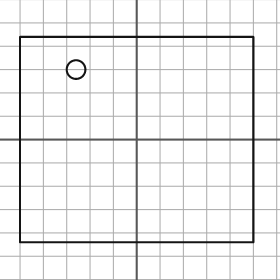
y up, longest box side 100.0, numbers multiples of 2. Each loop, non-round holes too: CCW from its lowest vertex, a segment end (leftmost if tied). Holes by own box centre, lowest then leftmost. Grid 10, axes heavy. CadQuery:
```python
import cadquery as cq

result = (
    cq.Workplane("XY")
    .moveTo(-50.0, -44.0)
    .lineTo(50.0, -44.0)
    .lineTo(50.0, 44.0)
    .lineTo(-50.0, 44.0)
    .close()
    .moveTo(-26.0, 30.0)
    .circle(4.0)
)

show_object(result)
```